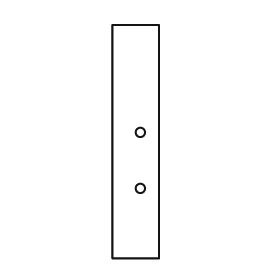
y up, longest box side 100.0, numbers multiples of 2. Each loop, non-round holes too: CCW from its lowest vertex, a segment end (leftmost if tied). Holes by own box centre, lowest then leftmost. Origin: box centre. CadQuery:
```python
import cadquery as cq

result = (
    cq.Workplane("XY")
    .moveTo(-10.0, -50.0)
    .lineTo(10.0, -50.0)
    .lineTo(10.0, 50.0)
    .lineTo(-10.0, 50.0)
    .close()
    .moveTo(2.0, -20.0)
    .circle(2.0)
    .moveTo(2.0, 4.0)
    .circle(2.0)
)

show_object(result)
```